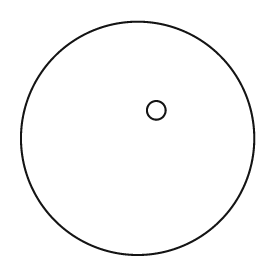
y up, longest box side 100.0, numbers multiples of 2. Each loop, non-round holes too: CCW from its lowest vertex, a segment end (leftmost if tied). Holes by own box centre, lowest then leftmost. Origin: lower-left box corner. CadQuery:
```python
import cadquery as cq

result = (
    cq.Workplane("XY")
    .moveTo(50.0, 50.0)
    .circle(50.0)
    .moveTo(58.0, 62.0)
    .circle(4.0)
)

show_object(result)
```